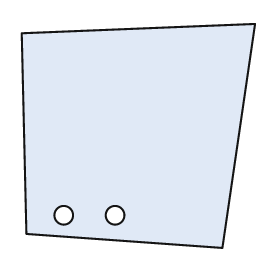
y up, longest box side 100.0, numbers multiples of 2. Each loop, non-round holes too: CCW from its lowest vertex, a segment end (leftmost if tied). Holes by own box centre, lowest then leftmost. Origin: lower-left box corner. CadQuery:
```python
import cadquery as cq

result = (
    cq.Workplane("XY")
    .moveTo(86.0, 0.0)
    .lineTo(100.0, 96.0)
    .lineTo(0.0, 92.0)
    .lineTo(2.0, 6.0)
    .close()
    .moveTo(18.0, 14.0)
    .circle(4.0)
    .moveTo(40.0, 14.0)
    .circle(4.0)
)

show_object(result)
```